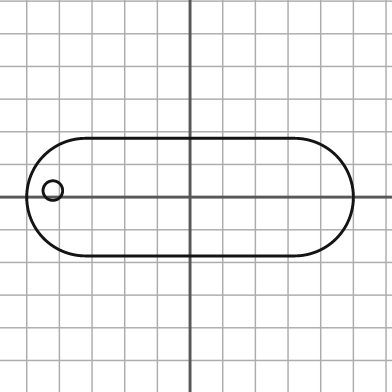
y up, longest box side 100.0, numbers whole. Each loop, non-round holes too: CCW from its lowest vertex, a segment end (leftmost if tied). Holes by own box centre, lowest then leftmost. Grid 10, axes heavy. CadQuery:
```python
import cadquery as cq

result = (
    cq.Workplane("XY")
    .moveTo(-32.0, -18.0)
    .lineTo(32.0, -18.0)
    .threePointArc((50.0, 0.0), (32.0, 18.0))
    .lineTo(-32.0, 18.0)
    .threePointArc((-50.0, 0.0), (-32.0, -18.0))
    .close()
    .moveTo(-42.0, 2.0)
    .circle(3.0)
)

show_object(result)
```